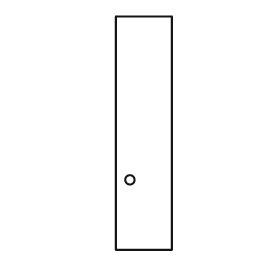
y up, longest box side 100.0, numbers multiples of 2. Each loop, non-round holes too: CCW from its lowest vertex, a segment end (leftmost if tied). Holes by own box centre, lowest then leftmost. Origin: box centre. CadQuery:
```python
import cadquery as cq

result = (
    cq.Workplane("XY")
    .moveTo(-12.0, -50.0)
    .lineTo(12.0, -50.0)
    .lineTo(12.0, 50.0)
    .lineTo(-12.0, 50.0)
    .close()
    .moveTo(-6.0, -20.0)
    .circle(2.0)
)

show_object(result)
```